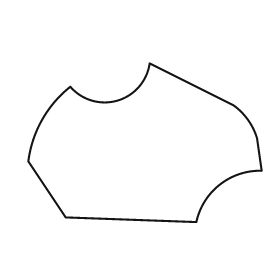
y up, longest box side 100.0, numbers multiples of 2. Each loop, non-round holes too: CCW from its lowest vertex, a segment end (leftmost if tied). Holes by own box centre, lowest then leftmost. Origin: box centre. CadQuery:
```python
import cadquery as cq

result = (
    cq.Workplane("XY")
    .moveTo(22.0, -34.0)
    .threePointArc((32.0, -18.0), (50.0, -12.0))
    .lineTo(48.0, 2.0)
    .threePointArc((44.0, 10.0), (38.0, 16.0))
    .lineTo(2.0, 34.0)
    .threePointArc((-12.0, 18.0), (-32.0, 24.0))
    .threePointArc((-44.0, 10.0), (-50.0, -8.0))
    .lineTo(-34.0, -32.0)
    .close()
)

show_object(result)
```